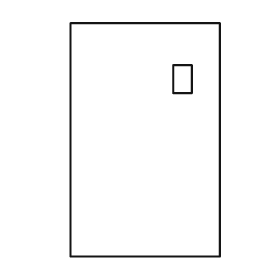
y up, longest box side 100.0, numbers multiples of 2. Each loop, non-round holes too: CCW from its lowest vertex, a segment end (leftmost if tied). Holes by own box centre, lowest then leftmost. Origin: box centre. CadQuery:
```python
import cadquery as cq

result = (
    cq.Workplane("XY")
    .moveTo(-32.0, -50.0)
    .lineTo(32.0, -50.0)
    .lineTo(32.0, 50.0)
    .lineTo(-32.0, 50.0)
    .close()
    .moveTo(12.0, 20.0)
    .lineTo(20.0, 20.0)
    .lineTo(20.0, 32.0)
    .lineTo(12.0, 32.0)
    .close()
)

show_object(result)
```